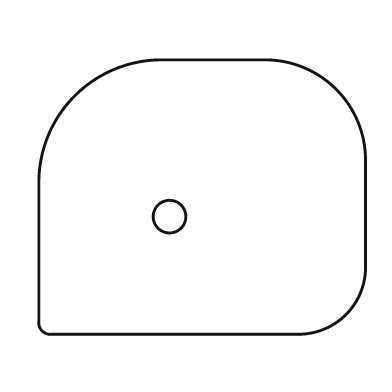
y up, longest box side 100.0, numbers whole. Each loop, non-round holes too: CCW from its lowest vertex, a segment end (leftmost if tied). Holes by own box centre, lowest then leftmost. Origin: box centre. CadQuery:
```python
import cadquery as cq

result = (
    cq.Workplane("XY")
    .moveTo(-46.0, -42.0)
    .lineTo(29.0, -42.0)
    .threePointArc((44.0, -36.0), (50.0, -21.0))
    .lineTo(50.0, 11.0)
    .threePointArc((41.0, 33.0), (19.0, 42.0))
    .lineTo(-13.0, 42.0)
    .threePointArc((-39.0, 31.0), (-50.0, 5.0))
    .lineTo(-50.0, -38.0)
    .threePointArc((-49.0, -41.0), (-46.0, -42.0))
    .close()
    .moveTo(-10.0, -6.0)
    .circle(5.0)
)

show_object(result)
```